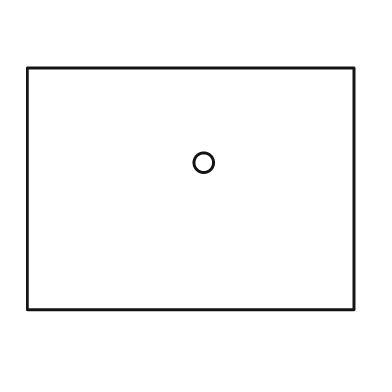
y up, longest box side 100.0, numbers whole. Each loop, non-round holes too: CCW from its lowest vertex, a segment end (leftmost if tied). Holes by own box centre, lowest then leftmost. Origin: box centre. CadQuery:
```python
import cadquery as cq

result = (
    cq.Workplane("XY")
    .moveTo(-50.0, -37.0)
    .lineTo(50.0, -37.0)
    .lineTo(50.0, 37.0)
    .lineTo(-50.0, 37.0)
    .close()
    .moveTo(4.0, 8.0)
    .circle(3.0)
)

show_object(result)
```